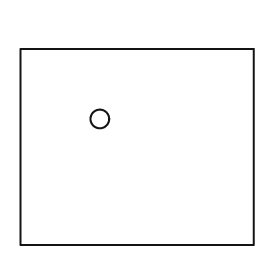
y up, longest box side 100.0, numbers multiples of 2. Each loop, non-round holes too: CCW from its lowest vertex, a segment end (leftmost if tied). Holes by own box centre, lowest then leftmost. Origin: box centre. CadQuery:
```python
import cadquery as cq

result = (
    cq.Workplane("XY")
    .moveTo(-50.0, -42.0)
    .lineTo(50.0, -42.0)
    .lineTo(50.0, 42.0)
    .lineTo(-50.0, 42.0)
    .close()
    .moveTo(-16.0, 12.0)
    .circle(4.0)
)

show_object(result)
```